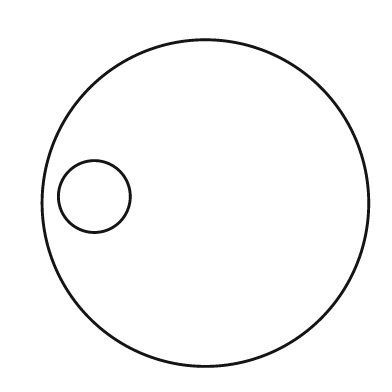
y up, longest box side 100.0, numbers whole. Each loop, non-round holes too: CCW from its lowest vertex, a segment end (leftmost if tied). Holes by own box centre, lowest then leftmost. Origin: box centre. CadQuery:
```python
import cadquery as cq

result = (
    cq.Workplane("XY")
    .moveTo(0.0, 0.0)
    .circle(50.0)
    .moveTo(-34.0, 2.0)
    .circle(11.0)
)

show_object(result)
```